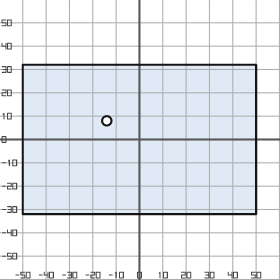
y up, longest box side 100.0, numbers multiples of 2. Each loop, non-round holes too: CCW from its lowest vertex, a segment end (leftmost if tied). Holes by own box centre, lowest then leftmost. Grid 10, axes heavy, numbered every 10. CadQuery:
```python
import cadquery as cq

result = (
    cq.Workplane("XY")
    .moveTo(-50.0, -32.0)
    .lineTo(50.0, -32.0)
    .lineTo(50.0, 32.0)
    .lineTo(-50.0, 32.0)
    .close()
    .moveTo(-14.0, 8.0)
    .circle(2.0)
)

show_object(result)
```